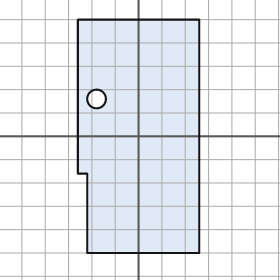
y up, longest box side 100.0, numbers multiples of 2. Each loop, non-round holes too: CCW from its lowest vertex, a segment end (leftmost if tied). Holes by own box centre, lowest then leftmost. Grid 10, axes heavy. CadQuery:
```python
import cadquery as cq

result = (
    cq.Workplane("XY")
    .moveTo(-22.0, -50.0)
    .lineTo(26.0, -50.0)
    .lineTo(26.0, 50.0)
    .lineTo(-26.0, 50.0)
    .lineTo(-26.0, -16.0)
    .lineTo(-22.0, -16.0)
    .close()
    .moveTo(-18.0, 16.0)
    .circle(4.0)
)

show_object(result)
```